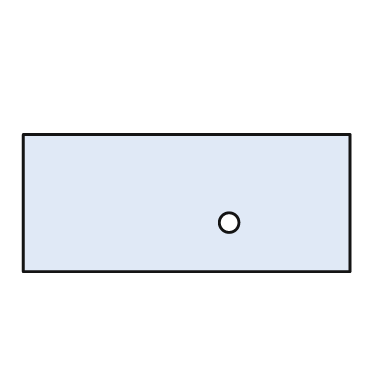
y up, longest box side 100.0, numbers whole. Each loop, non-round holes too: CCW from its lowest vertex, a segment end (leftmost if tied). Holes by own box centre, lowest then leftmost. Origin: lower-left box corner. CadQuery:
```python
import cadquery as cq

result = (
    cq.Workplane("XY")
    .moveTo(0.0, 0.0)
    .lineTo(100.0, 0.0)
    .lineTo(100.0, 42.0)
    .lineTo(0.0, 42.0)
    .close()
    .moveTo(63.0, 15.0)
    .circle(3.0)
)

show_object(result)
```